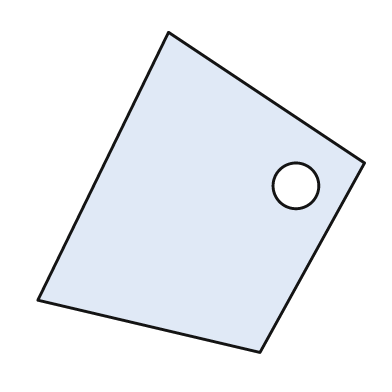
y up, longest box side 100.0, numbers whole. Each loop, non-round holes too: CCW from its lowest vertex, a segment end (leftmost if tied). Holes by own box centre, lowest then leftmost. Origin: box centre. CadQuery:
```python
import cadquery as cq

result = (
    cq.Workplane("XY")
    .moveTo(18.0, -49.0)
    .lineTo(50.0, 9.0)
    .lineTo(-10.0, 49.0)
    .lineTo(-50.0, -33.0)
    .close()
    .moveTo(29.0, 2.0)
    .circle(7.0)
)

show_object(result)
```